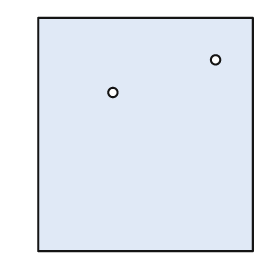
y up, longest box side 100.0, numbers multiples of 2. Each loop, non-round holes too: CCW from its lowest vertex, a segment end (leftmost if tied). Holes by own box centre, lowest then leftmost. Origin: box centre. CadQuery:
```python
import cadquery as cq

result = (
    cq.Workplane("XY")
    .moveTo(-46.0, -50.0)
    .lineTo(46.0, -50.0)
    .lineTo(46.0, 50.0)
    .lineTo(-46.0, 50.0)
    .close()
    .moveTo(-14.0, 18.0)
    .circle(2.0)
    .moveTo(30.0, 32.0)
    .circle(2.0)
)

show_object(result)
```